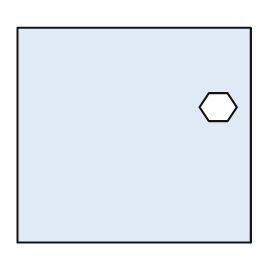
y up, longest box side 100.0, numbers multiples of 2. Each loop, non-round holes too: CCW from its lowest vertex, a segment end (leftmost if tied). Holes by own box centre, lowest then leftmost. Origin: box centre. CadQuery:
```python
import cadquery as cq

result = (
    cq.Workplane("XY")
    .moveTo(-50.0, -46.0)
    .lineTo(50.0, -46.0)
    .lineTo(50.0, 46.0)
    .lineTo(-50.0, 46.0)
    .close()
    .moveTo(32.0, 6.0)
    .lineTo(40.0, 6.0)
    .lineTo(44.0, 12.0)
    .lineTo(40.0, 18.0)
    .lineTo(32.0, 18.0)
    .lineTo(28.0, 12.0)
    .close()
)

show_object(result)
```